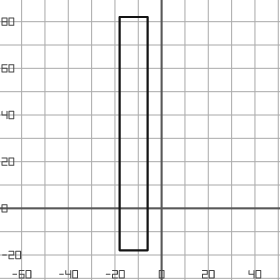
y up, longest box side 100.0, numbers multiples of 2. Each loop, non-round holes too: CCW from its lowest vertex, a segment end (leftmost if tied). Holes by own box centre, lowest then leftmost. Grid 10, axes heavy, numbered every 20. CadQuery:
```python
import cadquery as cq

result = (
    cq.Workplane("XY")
    .moveTo(-18.0, -18.0)
    .lineTo(-6.0, -18.0)
    .lineTo(-6.0, 82.0)
    .lineTo(-18.0, 82.0)
    .close()
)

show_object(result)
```